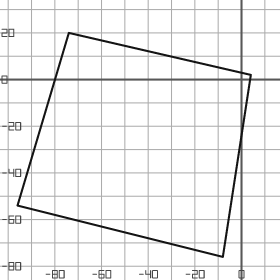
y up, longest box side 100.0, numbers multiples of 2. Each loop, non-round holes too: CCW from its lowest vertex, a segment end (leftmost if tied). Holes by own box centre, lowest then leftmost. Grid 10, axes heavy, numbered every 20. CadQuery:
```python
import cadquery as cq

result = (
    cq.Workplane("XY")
    .moveTo(-8.0, -76.0)
    .lineTo(4.0, 2.0)
    .lineTo(-74.0, 20.0)
    .lineTo(-96.0, -54.0)
    .close()
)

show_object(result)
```